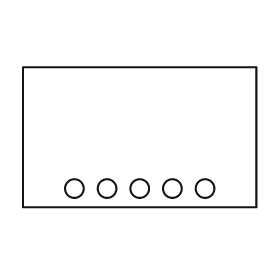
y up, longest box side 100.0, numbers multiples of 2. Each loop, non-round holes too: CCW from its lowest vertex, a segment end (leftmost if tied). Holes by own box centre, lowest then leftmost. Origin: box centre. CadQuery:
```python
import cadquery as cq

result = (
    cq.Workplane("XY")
    .moveTo(-50.0, -30.0)
    .lineTo(50.0, -30.0)
    .lineTo(50.0, 30.0)
    .lineTo(-50.0, 30.0)
    .close()
    .moveTo(-28.0, -22.0)
    .circle(4.0)
    .moveTo(-14.0, -22.0)
    .circle(4.0)
    .moveTo(0.0, -22.0)
    .circle(4.0)
    .moveTo(14.0, -22.0)
    .circle(4.0)
    .moveTo(28.0, -22.0)
    .circle(4.0)
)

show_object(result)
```